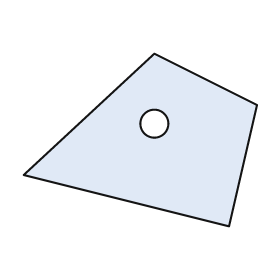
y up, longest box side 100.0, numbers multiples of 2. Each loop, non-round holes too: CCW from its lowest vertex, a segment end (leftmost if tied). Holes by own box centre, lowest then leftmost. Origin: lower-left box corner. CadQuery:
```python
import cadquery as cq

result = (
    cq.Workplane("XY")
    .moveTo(88.0, 0.0)
    .lineTo(100.0, 52.0)
    .lineTo(56.0, 74.0)
    .lineTo(0.0, 22.0)
    .close()
    .moveTo(56.0, 44.0)
    .circle(6.0)
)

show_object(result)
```